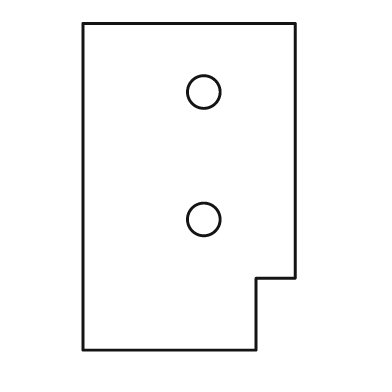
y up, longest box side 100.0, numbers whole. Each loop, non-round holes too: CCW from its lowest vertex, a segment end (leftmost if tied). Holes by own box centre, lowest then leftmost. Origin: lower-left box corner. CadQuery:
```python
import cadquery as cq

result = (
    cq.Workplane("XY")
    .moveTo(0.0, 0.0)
    .lineTo(53.0, 0.0)
    .lineTo(53.0, 22.0)
    .lineTo(65.0, 22.0)
    .lineTo(65.0, 100.0)
    .lineTo(0.0, 100.0)
    .close()
    .moveTo(37.0, 40.0)
    .circle(5.0)
    .moveTo(37.0, 79.0)
    .circle(5.0)
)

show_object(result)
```